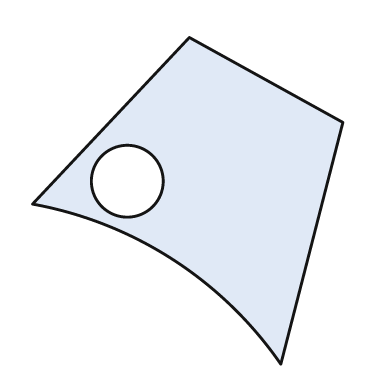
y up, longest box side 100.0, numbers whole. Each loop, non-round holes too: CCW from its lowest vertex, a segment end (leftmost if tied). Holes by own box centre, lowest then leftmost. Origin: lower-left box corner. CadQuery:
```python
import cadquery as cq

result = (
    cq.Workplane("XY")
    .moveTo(76.0, 0.0)
    .lineTo(95.0, 74.0)
    .lineTo(48.0, 100.0)
    .lineTo(0.0, 49.0)
    .threePointArc((43.0, 32.0), (76.0, 0.0))
    .close()
    .moveTo(29.0, 56.0)
    .circle(11.0)
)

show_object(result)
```